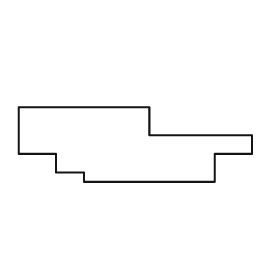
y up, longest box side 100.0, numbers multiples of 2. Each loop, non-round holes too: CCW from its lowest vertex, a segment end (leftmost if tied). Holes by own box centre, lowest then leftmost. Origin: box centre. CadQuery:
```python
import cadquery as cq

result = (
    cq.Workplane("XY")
    .moveTo(-22.0, -16.0)
    .lineTo(34.0, -16.0)
    .lineTo(34.0, -4.0)
    .lineTo(50.0, -4.0)
    .lineTo(50.0, 4.0)
    .lineTo(6.0, 4.0)
    .lineTo(6.0, 16.0)
    .lineTo(-50.0, 16.0)
    .lineTo(-50.0, -4.0)
    .lineTo(-34.0, -4.0)
    .lineTo(-34.0, -12.0)
    .lineTo(-22.0, -12.0)
    .close()
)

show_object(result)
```